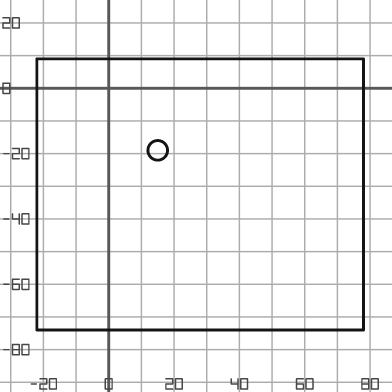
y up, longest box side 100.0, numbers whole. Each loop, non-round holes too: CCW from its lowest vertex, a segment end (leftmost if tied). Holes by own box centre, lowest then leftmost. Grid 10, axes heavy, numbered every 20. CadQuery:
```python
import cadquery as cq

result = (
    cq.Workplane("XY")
    .moveTo(-22.0, -74.0)
    .lineTo(78.0, -74.0)
    .lineTo(78.0, 9.0)
    .lineTo(-22.0, 9.0)
    .close()
    .moveTo(15.0, -19.0)
    .circle(3.0)
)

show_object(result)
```